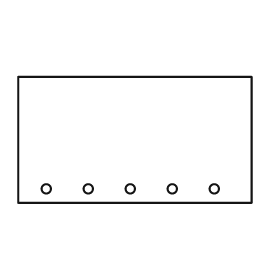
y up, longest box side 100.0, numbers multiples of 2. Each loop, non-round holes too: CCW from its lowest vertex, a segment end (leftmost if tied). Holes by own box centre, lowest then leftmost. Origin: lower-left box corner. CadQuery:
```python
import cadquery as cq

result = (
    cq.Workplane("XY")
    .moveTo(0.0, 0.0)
    .lineTo(100.0, 0.0)
    .lineTo(100.0, 54.0)
    .lineTo(0.0, 54.0)
    .close()
    .moveTo(12.0, 6.0)
    .circle(2.0)
    .moveTo(30.0, 6.0)
    .circle(2.0)
    .moveTo(48.0, 6.0)
    .circle(2.0)
    .moveTo(66.0, 6.0)
    .circle(2.0)
    .moveTo(84.0, 6.0)
    .circle(2.0)
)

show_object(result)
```